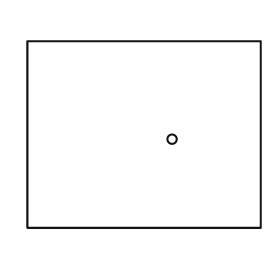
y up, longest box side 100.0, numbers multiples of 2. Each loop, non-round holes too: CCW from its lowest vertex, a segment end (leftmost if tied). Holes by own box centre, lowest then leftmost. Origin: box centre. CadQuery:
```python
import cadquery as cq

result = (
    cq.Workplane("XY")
    .moveTo(-50.0, -40.0)
    .lineTo(50.0, -40.0)
    .lineTo(50.0, 40.0)
    .lineTo(-50.0, 40.0)
    .close()
    .moveTo(12.0, -2.0)
    .circle(2.0)
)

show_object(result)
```